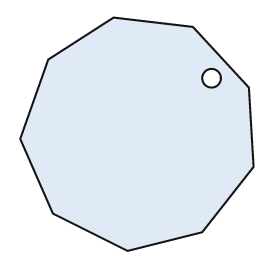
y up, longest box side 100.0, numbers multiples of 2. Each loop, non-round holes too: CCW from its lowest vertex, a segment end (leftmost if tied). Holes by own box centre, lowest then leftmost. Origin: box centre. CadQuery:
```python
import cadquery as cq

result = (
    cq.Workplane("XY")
    .moveTo(-4.0, -50.0)
    .lineTo(28.0, -42.0)
    .lineTo(50.0, -14.0)
    .lineTo(48.0, 20.0)
    .lineTo(24.0, 46.0)
    .lineTo(-10.0, 50.0)
    .lineTo(-38.0, 32.0)
    .lineTo(-50.0, -2.0)
    .lineTo(-36.0, -34.0)
    .close()
    .moveTo(32.0, 24.0)
    .circle(4.0)
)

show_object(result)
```